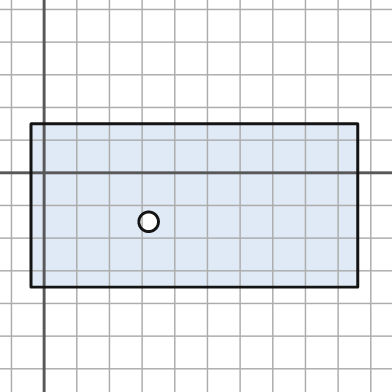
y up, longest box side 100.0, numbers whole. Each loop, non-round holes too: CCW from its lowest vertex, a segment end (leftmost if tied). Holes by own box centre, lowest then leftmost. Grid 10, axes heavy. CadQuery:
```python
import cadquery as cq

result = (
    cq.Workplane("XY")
    .moveTo(-4.0, -35.0)
    .lineTo(96.0, -35.0)
    .lineTo(96.0, 15.0)
    .lineTo(-4.0, 15.0)
    .close()
    .moveTo(32.0, -15.0)
    .circle(3.0)
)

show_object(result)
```